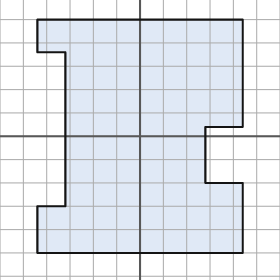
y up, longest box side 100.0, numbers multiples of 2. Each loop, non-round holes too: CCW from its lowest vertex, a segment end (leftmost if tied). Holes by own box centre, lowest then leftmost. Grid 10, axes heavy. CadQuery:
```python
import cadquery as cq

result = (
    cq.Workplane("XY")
    .moveTo(-44.0, -50.0)
    .lineTo(44.0, -50.0)
    .lineTo(44.0, -20.0)
    .lineTo(28.0, -20.0)
    .lineTo(28.0, 4.0)
    .lineTo(44.0, 4.0)
    .lineTo(44.0, 50.0)
    .lineTo(-44.0, 50.0)
    .lineTo(-44.0, 36.0)
    .lineTo(-32.0, 36.0)
    .lineTo(-32.0, -30.0)
    .lineTo(-44.0, -30.0)
    .close()
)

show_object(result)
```